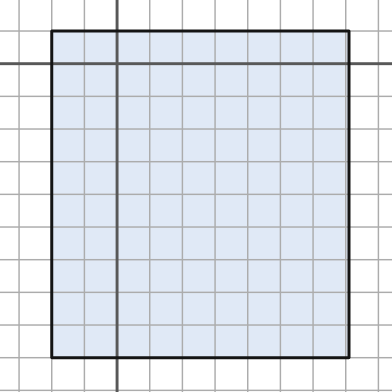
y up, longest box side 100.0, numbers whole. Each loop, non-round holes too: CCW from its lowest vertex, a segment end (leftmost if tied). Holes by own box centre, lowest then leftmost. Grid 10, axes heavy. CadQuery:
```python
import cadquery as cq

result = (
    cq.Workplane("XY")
    .moveTo(-20.0, -90.0)
    .lineTo(71.0, -90.0)
    .lineTo(71.0, 10.0)
    .lineTo(-20.0, 10.0)
    .close()
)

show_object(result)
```